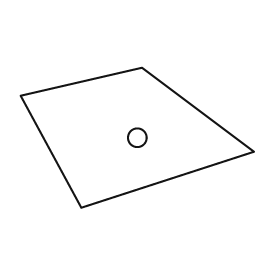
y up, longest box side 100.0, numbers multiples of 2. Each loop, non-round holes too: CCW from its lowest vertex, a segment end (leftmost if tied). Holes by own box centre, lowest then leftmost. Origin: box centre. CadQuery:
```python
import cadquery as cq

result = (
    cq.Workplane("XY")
    .moveTo(-24.0, -30.0)
    .lineTo(50.0, -6.0)
    .lineTo(2.0, 30.0)
    .lineTo(-50.0, 18.0)
    .close()
    .moveTo(0.0, 0.0)
    .circle(4.0)
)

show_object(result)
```